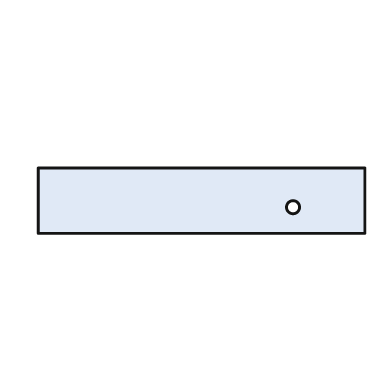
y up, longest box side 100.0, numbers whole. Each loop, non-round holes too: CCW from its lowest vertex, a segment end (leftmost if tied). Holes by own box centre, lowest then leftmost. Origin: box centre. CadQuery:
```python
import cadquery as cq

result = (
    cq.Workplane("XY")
    .moveTo(-50.0, -10.0)
    .lineTo(50.0, -10.0)
    .lineTo(50.0, 10.0)
    .lineTo(-50.0, 10.0)
    .close()
    .moveTo(28.0, -2.0)
    .circle(2.0)
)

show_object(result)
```